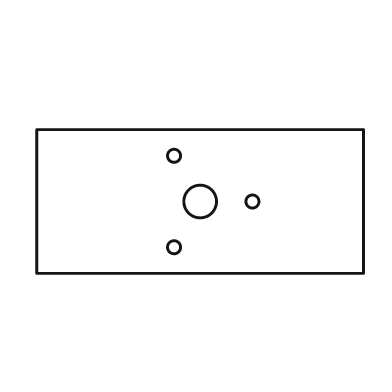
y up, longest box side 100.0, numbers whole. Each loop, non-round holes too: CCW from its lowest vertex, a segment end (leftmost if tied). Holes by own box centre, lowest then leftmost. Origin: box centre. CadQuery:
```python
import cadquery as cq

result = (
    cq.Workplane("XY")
    .moveTo(-50.0, -22.0)
    .lineTo(50.0, -22.0)
    .lineTo(50.0, 22.0)
    .lineTo(-50.0, 22.0)
    .close()
    .moveTo(-8.0, -14.0)
    .circle(2.0)
    .moveTo(0.0, 0.0)
    .circle(5.0)
    .moveTo(16.0, 0.0)
    .circle(2.0)
    .moveTo(-8.0, 14.0)
    .circle(2.0)
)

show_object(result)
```